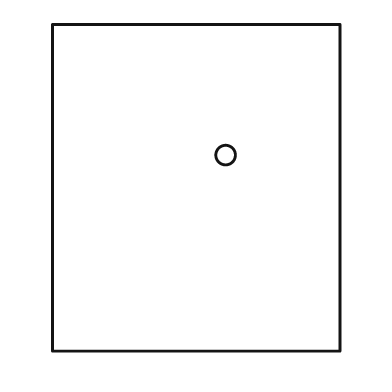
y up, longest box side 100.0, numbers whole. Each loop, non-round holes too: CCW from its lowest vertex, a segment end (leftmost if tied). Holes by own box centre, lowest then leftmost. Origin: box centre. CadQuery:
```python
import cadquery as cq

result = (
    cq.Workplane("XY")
    .moveTo(-44.0, -50.0)
    .lineTo(44.0, -50.0)
    .lineTo(44.0, 50.0)
    .lineTo(-44.0, 50.0)
    .close()
    .moveTo(9.0, 10.0)
    .circle(3.0)
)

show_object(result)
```